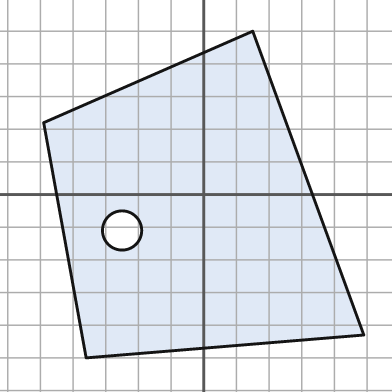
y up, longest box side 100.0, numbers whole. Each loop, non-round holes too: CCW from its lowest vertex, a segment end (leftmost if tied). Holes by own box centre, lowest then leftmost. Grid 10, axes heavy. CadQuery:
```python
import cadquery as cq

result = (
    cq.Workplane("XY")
    .moveTo(-36.0, -50.0)
    .lineTo(49.0, -43.0)
    .lineTo(15.0, 50.0)
    .lineTo(-49.0, 22.0)
    .close()
    .moveTo(-25.0, -11.0)
    .circle(6.0)
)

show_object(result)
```